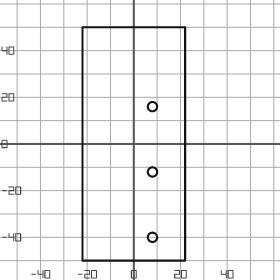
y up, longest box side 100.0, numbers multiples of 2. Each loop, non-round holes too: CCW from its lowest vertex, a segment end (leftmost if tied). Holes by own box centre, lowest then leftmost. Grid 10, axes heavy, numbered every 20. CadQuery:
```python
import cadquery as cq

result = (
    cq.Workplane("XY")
    .moveTo(-22.0, -50.0)
    .lineTo(22.0, -50.0)
    .lineTo(22.0, 50.0)
    .lineTo(-22.0, 50.0)
    .close()
    .moveTo(8.0, -40.0)
    .circle(2.0)
    .moveTo(8.0, -12.0)
    .circle(2.0)
    .moveTo(8.0, 16.0)
    .circle(2.0)
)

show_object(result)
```